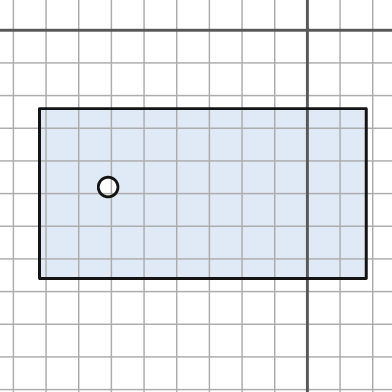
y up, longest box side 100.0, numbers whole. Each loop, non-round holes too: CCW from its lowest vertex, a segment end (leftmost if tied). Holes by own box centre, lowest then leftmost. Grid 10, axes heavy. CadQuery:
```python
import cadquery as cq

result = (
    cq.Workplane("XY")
    .moveTo(-82.0, -76.0)
    .lineTo(18.0, -76.0)
    .lineTo(18.0, -24.0)
    .lineTo(-82.0, -24.0)
    .close()
    .moveTo(-61.0, -48.0)
    .circle(3.0)
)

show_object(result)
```